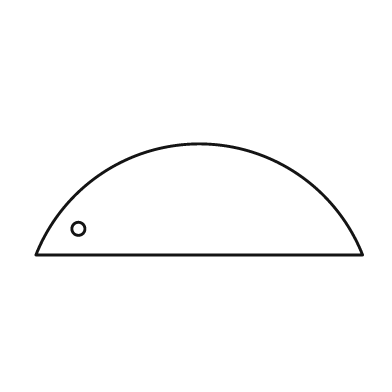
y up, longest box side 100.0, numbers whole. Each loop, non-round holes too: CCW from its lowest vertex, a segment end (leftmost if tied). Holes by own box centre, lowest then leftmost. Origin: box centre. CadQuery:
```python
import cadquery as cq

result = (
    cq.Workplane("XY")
    .moveTo(-50.0, -17.0)
    .lineTo(50.0, -17.0)
    .threePointArc((0.0, 17.0), (-50.0, -17.0))
    .close()
    .moveTo(-37.0, -9.0)
    .circle(2.0)
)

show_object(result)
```